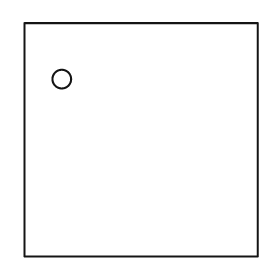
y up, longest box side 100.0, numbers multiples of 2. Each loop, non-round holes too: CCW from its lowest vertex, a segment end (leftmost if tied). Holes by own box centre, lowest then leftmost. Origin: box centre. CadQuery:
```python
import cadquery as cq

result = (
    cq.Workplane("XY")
    .moveTo(-50.0, -50.0)
    .lineTo(50.0, -50.0)
    .lineTo(50.0, 50.0)
    .lineTo(-50.0, 50.0)
    .close()
    .moveTo(-34.0, 26.0)
    .circle(4.0)
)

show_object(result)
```